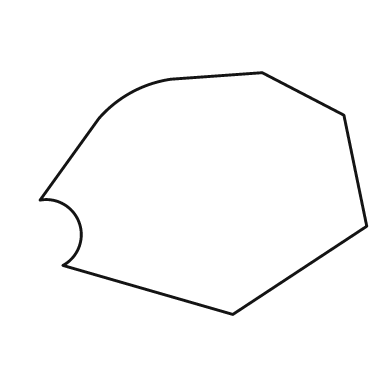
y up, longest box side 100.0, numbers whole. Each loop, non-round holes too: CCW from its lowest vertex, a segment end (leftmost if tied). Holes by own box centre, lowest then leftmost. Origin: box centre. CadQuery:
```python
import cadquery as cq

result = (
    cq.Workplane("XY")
    .moveTo(9.0, -37.0)
    .lineTo(50.0, -10.0)
    .lineTo(43.0, 24.0)
    .lineTo(18.0, 37.0)
    .lineTo(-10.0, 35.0)
    .threePointArc((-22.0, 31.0), (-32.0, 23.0))
    .lineTo(-50.0, -2.0)
    .threePointArc((-38.0, -9.0), (-43.0, -22.0))
    .close()
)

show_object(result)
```